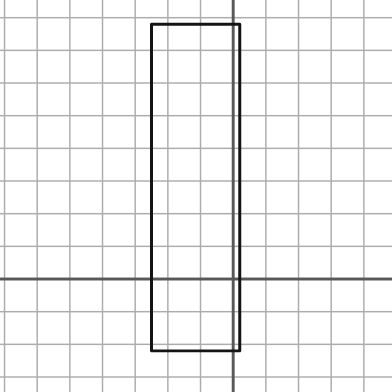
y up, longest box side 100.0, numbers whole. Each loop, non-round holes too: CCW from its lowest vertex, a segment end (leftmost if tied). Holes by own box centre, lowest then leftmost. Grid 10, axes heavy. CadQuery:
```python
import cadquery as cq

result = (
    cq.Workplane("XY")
    .moveTo(-25.0, -22.0)
    .lineTo(2.0, -22.0)
    .lineTo(2.0, 78.0)
    .lineTo(-25.0, 78.0)
    .close()
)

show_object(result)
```